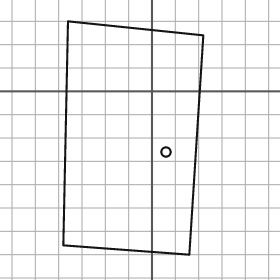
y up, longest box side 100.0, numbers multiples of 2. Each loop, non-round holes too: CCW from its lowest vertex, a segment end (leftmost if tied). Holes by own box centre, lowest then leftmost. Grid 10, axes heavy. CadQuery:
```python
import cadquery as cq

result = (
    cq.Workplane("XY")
    .moveTo(16.0, -70.0)
    .lineTo(22.0, 24.0)
    .lineTo(-36.0, 30.0)
    .lineTo(-38.0, -66.0)
    .close()
    .moveTo(6.0, -26.0)
    .circle(2.0)
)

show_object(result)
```